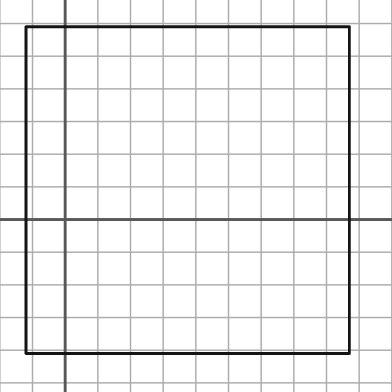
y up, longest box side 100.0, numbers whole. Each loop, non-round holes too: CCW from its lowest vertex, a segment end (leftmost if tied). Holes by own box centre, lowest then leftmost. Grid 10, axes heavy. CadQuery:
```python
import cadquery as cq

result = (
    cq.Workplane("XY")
    .moveTo(-12.0, -41.0)
    .lineTo(87.0, -41.0)
    .lineTo(87.0, 59.0)
    .lineTo(-12.0, 59.0)
    .close()
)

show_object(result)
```